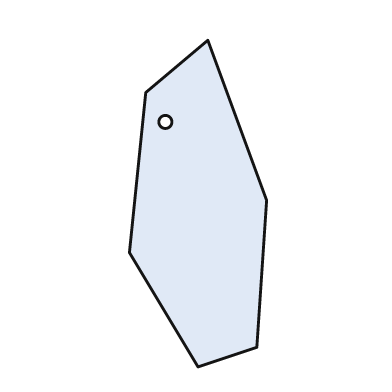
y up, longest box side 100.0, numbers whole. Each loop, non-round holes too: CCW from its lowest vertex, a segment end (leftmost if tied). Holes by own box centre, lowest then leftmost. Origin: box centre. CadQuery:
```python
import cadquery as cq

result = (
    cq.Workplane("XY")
    .moveTo(0.0, -50.0)
    .lineTo(18.0, -44.0)
    .lineTo(21.0, 1.0)
    .lineTo(3.0, 50.0)
    .lineTo(-16.0, 34.0)
    .lineTo(-21.0, -15.0)
    .close()
    .moveTo(-10.0, 25.0)
    .circle(2.0)
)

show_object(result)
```